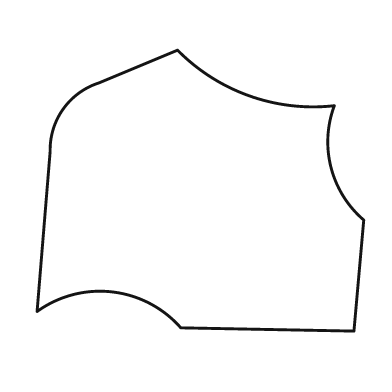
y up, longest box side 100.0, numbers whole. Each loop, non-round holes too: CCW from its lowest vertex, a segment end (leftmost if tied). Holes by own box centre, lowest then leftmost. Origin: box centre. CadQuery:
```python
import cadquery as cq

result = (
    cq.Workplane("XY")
    .moveTo(47.0, -43.0)
    .lineTo(50.0, -9.0)
    .threePointArc((40.0, 7.0), (41.0, 26.0))
    .threePointArc((15.0, 29.0), (-7.0, 43.0))
    .lineTo(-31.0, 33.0)
    .threePointArc((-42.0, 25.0), (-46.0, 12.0))
    .lineTo(-50.0, -37.0)
    .threePointArc((-27.0, -31.0), (-6.0, -42.0))
    .close()
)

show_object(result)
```